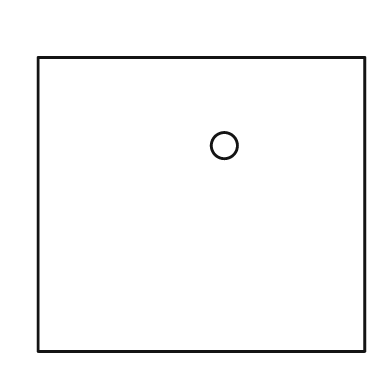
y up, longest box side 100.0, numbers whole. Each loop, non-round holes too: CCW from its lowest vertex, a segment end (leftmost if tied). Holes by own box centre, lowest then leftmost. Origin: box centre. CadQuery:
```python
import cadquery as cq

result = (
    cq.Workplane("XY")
    .moveTo(-50.0, -45.0)
    .lineTo(50.0, -45.0)
    .lineTo(50.0, 45.0)
    .lineTo(-50.0, 45.0)
    .close()
    .moveTo(7.0, 18.0)
    .circle(4.0)
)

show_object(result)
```